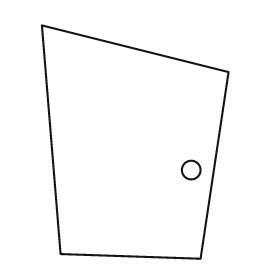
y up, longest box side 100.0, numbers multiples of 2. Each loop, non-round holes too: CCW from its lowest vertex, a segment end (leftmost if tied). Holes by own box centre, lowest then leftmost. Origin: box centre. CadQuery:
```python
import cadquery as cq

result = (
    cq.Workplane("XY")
    .moveTo(28.0, -50.0)
    .lineTo(40.0, 30.0)
    .lineTo(-40.0, 50.0)
    .lineTo(-32.0, -48.0)
    .close()
    .moveTo(24.0, -12.0)
    .circle(4.0)
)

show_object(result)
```